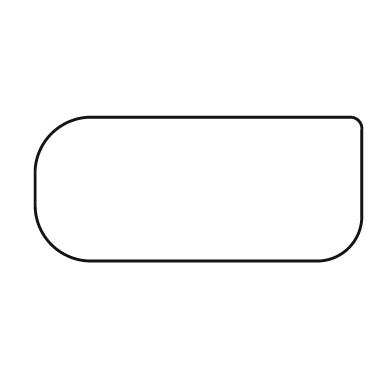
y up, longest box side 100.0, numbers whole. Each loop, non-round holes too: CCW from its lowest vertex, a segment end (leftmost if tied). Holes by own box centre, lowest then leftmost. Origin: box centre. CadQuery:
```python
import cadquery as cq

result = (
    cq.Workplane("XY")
    .moveTo(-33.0, -22.0)
    .lineTo(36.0, -22.0)
    .threePointArc((46.0, -18.0), (50.0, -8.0))
    .lineTo(50.0, 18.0)
    .threePointArc((49.0, 21.0), (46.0, 22.0))
    .lineTo(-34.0, 22.0)
    .threePointArc((-45.0, 17.0), (-50.0, 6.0))
    .lineTo(-50.0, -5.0)
    .threePointArc((-45.0, -17.0), (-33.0, -22.0))
    .close()
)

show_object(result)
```